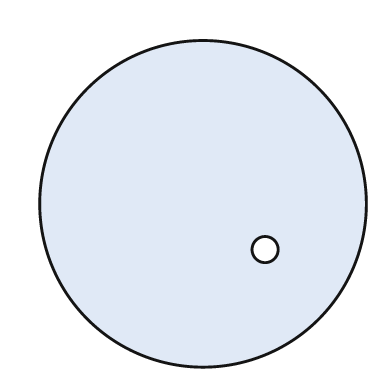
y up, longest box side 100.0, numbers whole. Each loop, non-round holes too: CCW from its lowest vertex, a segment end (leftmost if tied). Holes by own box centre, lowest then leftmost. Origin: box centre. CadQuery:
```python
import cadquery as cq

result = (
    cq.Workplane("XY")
    .moveTo(0.0, 0.0)
    .circle(50.0)
    .moveTo(19.0, -14.0)
    .circle(4.0)
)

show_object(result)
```